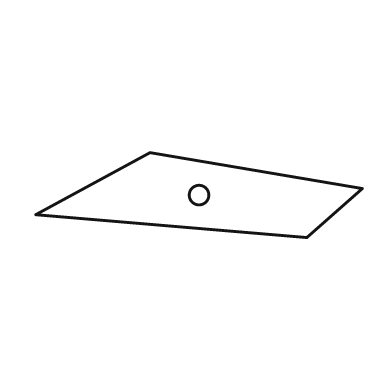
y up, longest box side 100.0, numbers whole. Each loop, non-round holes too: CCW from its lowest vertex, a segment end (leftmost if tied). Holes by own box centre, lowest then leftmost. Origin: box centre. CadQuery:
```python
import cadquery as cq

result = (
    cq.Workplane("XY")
    .moveTo(33.0, -13.0)
    .lineTo(50.0, 2.0)
    .lineTo(-15.0, 13.0)
    .lineTo(-50.0, -6.0)
    .close()
    .moveTo(0.0, 0.0)
    .circle(3.0)
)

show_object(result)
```